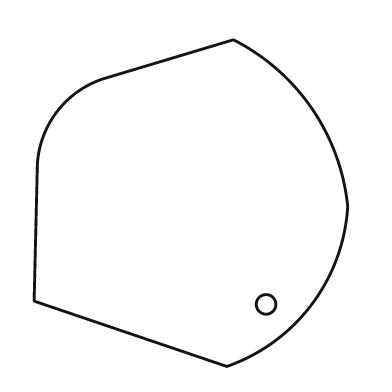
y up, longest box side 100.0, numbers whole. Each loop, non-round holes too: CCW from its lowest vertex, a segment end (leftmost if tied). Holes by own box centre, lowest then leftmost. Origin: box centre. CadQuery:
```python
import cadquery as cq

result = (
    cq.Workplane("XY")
    .moveTo(11.0, -50.0)
    .threePointArc((37.0, -31.0), (48.0, -1.0))
    .threePointArc((37.0, 29.0), (13.0, 50.0))
    .lineTo(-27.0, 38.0)
    .threePointArc((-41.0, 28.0), (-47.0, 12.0))
    .lineTo(-48.0, -30.0)
    .close()
    .moveTo(23.0, -31.0)
    .circle(3.0)
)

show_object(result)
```